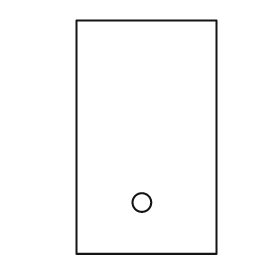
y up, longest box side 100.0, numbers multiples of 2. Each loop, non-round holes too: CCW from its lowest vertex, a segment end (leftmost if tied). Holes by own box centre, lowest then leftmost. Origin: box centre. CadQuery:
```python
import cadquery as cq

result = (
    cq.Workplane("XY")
    .moveTo(-30.0, -50.0)
    .lineTo(30.0, -50.0)
    .lineTo(30.0, 50.0)
    .lineTo(-30.0, 50.0)
    .close()
    .moveTo(-2.0, -28.0)
    .circle(4.0)
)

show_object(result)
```